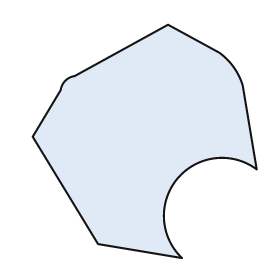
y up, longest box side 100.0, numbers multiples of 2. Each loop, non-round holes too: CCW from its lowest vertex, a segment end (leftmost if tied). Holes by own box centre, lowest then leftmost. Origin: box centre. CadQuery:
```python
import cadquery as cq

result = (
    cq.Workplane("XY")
    .moveTo(16.0, -50.0)
    .threePointArc((14.0, -16.0), (48.0, -12.0))
    .lineTo(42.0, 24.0)
    .threePointArc((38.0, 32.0), (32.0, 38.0))
    .lineTo(10.0, 50.0)
    .lineTo(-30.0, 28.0)
    .threePointArc((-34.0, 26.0), (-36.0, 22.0))
    .lineTo(-48.0, 2.0)
    .lineTo(-20.0, -44.0)
    .close()
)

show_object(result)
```